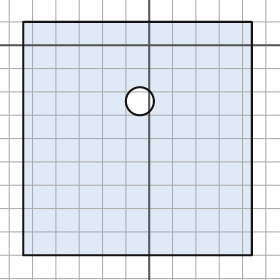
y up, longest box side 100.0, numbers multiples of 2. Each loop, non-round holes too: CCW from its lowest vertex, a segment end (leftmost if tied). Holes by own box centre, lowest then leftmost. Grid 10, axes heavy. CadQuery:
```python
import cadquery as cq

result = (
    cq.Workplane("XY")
    .moveTo(-54.0, -90.0)
    .lineTo(44.0, -90.0)
    .lineTo(44.0, 10.0)
    .lineTo(-54.0, 10.0)
    .close()
    .moveTo(-4.0, -24.0)
    .circle(6.0)
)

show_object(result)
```